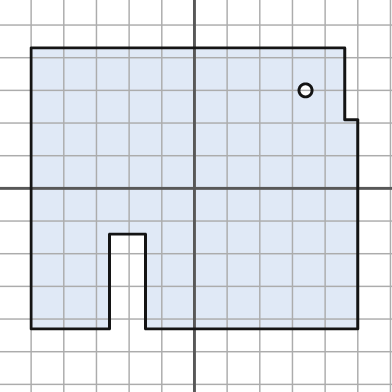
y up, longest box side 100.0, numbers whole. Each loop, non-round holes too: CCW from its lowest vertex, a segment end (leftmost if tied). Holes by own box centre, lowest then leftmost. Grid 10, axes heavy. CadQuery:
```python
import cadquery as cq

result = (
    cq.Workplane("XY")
    .moveTo(-50.0, -43.0)
    .lineTo(-26.0, -43.0)
    .lineTo(-26.0, -14.0)
    .lineTo(-15.0, -14.0)
    .lineTo(-15.0, -43.0)
    .lineTo(50.0, -43.0)
    .lineTo(50.0, 21.0)
    .lineTo(46.0, 21.0)
    .lineTo(46.0, 43.0)
    .lineTo(-50.0, 43.0)
    .close()
    .moveTo(34.0, 30.0)
    .circle(2.0)
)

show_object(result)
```